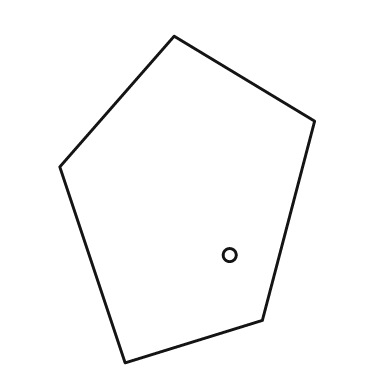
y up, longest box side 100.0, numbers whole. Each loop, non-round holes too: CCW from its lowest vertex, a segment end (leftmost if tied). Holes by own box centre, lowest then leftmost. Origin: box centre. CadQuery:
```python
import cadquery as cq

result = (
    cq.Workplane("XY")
    .moveTo(-19.0, -50.0)
    .lineTo(23.0, -37.0)
    .lineTo(39.0, 24.0)
    .lineTo(-4.0, 50.0)
    .lineTo(-39.0, 10.0)
    .close()
    .moveTo(13.0, -17.0)
    .circle(2.0)
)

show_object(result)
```